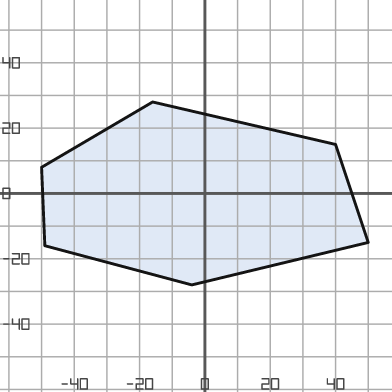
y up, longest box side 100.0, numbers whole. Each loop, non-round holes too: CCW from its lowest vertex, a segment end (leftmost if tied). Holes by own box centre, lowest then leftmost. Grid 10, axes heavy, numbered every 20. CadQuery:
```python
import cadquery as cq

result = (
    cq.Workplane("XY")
    .moveTo(-4.0, -28.0)
    .lineTo(50.0, -15.0)
    .lineTo(40.0, 15.0)
    .lineTo(-16.0, 28.0)
    .lineTo(-50.0, 8.0)
    .lineTo(-49.0, -16.0)
    .close()
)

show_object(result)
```